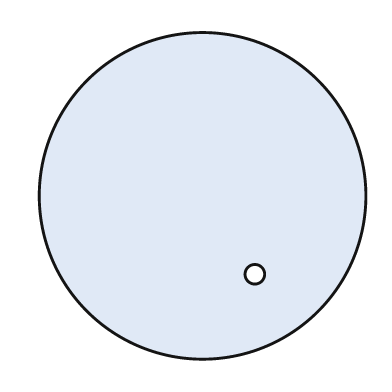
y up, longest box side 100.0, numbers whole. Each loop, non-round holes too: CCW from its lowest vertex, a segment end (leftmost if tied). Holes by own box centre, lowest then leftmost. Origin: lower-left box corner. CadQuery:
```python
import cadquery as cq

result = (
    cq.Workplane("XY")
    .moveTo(50.0, 50.0)
    .circle(50.0)
    .moveTo(66.0, 26.0)
    .circle(3.0)
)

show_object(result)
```